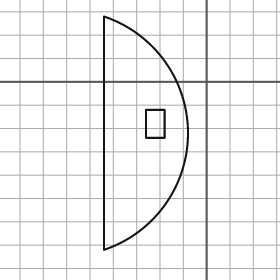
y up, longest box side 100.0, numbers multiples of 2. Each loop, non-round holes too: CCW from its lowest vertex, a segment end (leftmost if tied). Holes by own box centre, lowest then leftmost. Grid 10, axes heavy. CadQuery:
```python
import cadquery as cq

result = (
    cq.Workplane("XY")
    .moveTo(-44.0, -72.0)
    .threePointArc((-8.0, -22.0), (-44.0, 28.0))
    .close()
    .moveTo(-26.0, -24.0)
    .lineTo(-18.0, -24.0)
    .lineTo(-18.0, -12.0)
    .lineTo(-26.0, -12.0)
    .close()
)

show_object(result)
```